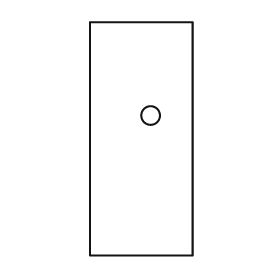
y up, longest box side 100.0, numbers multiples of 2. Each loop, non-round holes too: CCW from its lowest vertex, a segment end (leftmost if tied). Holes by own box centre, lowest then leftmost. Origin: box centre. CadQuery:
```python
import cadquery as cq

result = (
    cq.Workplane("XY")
    .moveTo(-22.0, -50.0)
    .lineTo(22.0, -50.0)
    .lineTo(22.0, 50.0)
    .lineTo(-22.0, 50.0)
    .close()
    .moveTo(4.0, 10.0)
    .circle(4.0)
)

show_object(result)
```